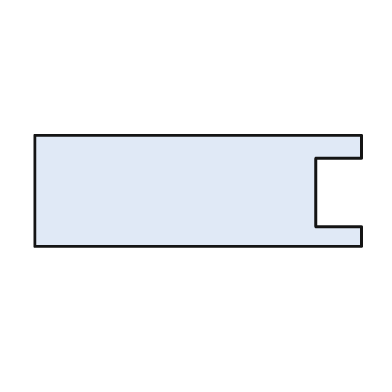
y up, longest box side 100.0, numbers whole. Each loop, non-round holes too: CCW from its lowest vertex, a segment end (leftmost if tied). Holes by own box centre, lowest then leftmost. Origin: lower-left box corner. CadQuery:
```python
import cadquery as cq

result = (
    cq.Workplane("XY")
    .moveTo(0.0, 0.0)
    .lineTo(100.0, 0.0)
    .lineTo(100.0, 6.0)
    .lineTo(86.0, 6.0)
    .lineTo(86.0, 27.0)
    .lineTo(100.0, 27.0)
    .lineTo(100.0, 34.0)
    .lineTo(0.0, 34.0)
    .close()
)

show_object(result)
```